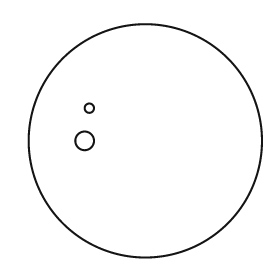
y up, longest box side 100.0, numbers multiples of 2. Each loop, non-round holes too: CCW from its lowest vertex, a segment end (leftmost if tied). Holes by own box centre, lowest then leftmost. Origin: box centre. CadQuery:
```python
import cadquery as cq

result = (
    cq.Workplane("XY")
    .moveTo(0.0, 0.0)
    .circle(50.0)
    .moveTo(-26.0, 0.0)
    .circle(4.0)
    .moveTo(-24.0, 14.0)
    .circle(2.0)
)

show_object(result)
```